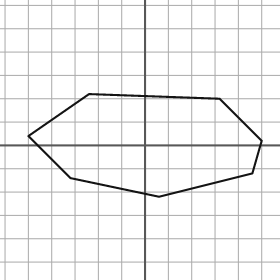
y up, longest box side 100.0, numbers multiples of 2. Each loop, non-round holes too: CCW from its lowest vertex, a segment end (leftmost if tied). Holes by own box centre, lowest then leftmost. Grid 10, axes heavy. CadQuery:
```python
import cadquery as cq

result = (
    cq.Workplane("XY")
    .moveTo(6.0, -22.0)
    .lineTo(46.0, -12.0)
    .lineTo(50.0, 2.0)
    .lineTo(32.0, 20.0)
    .lineTo(-24.0, 22.0)
    .lineTo(-50.0, 4.0)
    .lineTo(-32.0, -14.0)
    .close()
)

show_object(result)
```